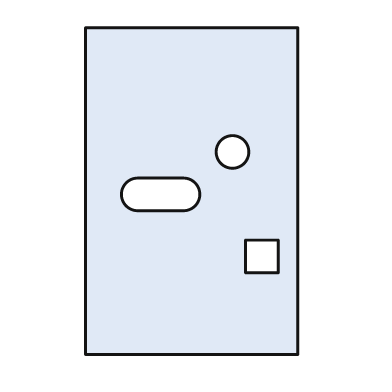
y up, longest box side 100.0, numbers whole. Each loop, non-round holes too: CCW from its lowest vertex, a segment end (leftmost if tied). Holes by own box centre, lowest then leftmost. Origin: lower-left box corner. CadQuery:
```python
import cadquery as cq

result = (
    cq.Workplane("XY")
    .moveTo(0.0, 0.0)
    .lineTo(65.0, 0.0)
    .lineTo(65.0, 100.0)
    .lineTo(0.0, 100.0)
    .close()
    .moveTo(49.0, 25.0)
    .lineTo(59.0, 25.0)
    .lineTo(59.0, 35.0)
    .lineTo(49.0, 35.0)
    .close()
    .moveTo(16.0, 44.0)
    .lineTo(30.0, 44.0)
    .threePointArc((35.0, 49.0), (30.0, 54.0))
    .lineTo(16.0, 54.0)
    .threePointArc((11.0, 49.0), (16.0, 44.0))
    .close()
    .moveTo(45.0, 62.0)
    .circle(5.0)
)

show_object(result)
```